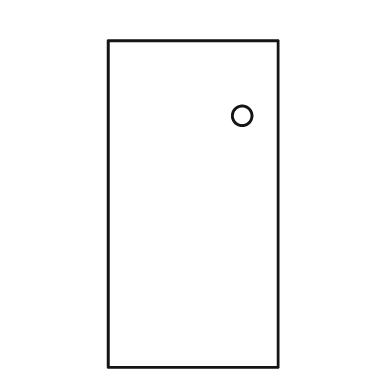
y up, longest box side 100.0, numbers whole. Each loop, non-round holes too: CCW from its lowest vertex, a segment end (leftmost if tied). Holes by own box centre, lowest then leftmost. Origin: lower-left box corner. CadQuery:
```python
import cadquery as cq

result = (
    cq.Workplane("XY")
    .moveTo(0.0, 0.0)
    .lineTo(52.0, 0.0)
    .lineTo(52.0, 100.0)
    .lineTo(0.0, 100.0)
    .close()
    .moveTo(41.0, 77.0)
    .circle(3.0)
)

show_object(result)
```